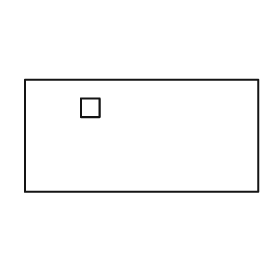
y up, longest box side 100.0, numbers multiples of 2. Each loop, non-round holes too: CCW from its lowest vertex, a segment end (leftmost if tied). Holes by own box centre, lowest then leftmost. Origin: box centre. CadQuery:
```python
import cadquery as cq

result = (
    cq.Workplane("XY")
    .moveTo(-50.0, -24.0)
    .lineTo(50.0, -24.0)
    .lineTo(50.0, 24.0)
    .lineTo(-50.0, 24.0)
    .close()
    .moveTo(-26.0, 8.0)
    .lineTo(-18.0, 8.0)
    .lineTo(-18.0, 16.0)
    .lineTo(-26.0, 16.0)
    .close()
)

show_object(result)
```